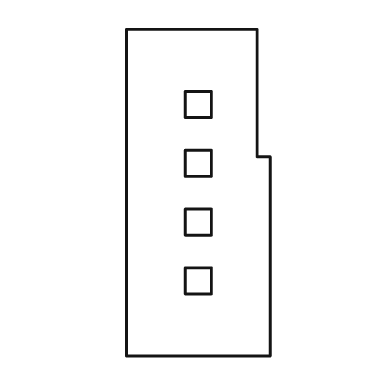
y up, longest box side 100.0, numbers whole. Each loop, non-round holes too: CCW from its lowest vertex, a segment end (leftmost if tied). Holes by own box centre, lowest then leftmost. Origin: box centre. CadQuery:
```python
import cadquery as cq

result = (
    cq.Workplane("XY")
    .moveTo(-22.0, -50.0)
    .lineTo(22.0, -50.0)
    .lineTo(22.0, 11.0)
    .lineTo(18.0, 11.0)
    .lineTo(18.0, 50.0)
    .lineTo(-22.0, 50.0)
    .close()
    .moveTo(-4.0, -31.0)
    .lineTo(4.0, -31.0)
    .lineTo(4.0, -23.0)
    .lineTo(-4.0, -23.0)
    .close()
    .moveTo(-4.0, -13.0)
    .lineTo(4.0, -13.0)
    .lineTo(4.0, -5.0)
    .lineTo(-4.0, -5.0)
    .close()
    .moveTo(-4.0, 5.0)
    .lineTo(4.0, 5.0)
    .lineTo(4.0, 13.0)
    .lineTo(-4.0, 13.0)
    .close()
    .moveTo(-4.0, 23.0)
    .lineTo(4.0, 23.0)
    .lineTo(4.0, 31.0)
    .lineTo(-4.0, 31.0)
    .close()
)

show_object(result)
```